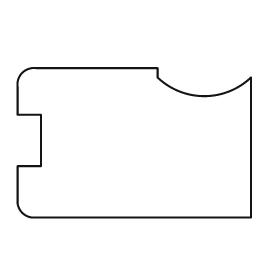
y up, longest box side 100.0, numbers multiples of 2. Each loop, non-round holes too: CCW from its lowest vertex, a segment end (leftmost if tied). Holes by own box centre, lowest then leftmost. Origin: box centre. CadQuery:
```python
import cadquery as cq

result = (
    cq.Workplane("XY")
    .moveTo(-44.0, -32.0)
    .lineTo(50.0, -32.0)
    .lineTo(50.0, 28.0)
    .threePointArc((30.0, 20.0), (10.0, 28.0))
    .lineTo(10.0, 32.0)
    .lineTo(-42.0, 32.0)
    .threePointArc((-48.0, 30.0), (-50.0, 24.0))
    .lineTo(-50.0, 12.0)
    .lineTo(-40.0, 12.0)
    .lineTo(-40.0, -10.0)
    .lineTo(-50.0, -10.0)
    .lineTo(-50.0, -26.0)
    .threePointArc((-48.0, -30.0), (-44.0, -32.0))
    .close()
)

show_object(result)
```